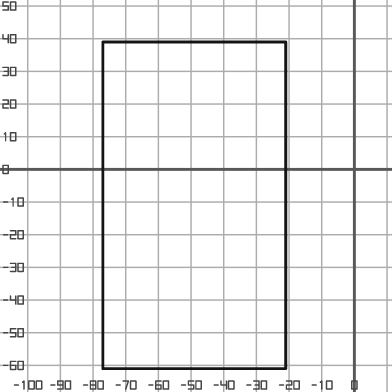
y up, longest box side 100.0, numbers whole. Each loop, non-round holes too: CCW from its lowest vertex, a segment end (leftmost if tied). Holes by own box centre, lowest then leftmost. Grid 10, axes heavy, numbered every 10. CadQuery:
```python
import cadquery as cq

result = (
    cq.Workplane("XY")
    .moveTo(-77.0, -61.0)
    .lineTo(-21.0, -61.0)
    .lineTo(-21.0, 39.0)
    .lineTo(-77.0, 39.0)
    .close()
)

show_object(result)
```